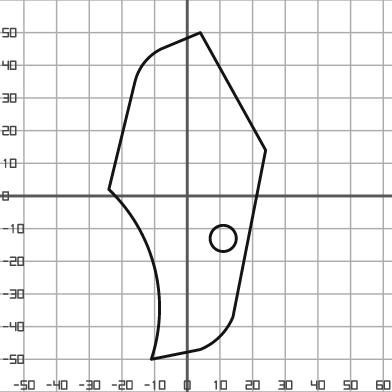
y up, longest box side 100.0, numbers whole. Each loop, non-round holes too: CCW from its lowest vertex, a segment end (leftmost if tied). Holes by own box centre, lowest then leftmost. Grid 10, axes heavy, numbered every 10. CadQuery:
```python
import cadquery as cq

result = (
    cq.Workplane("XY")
    .moveTo(-11.0, -50.0)
    .lineTo(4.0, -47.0)
    .threePointArc((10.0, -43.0), (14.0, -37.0))
    .lineTo(24.0, 14.0)
    .lineTo(4.0, 50.0)
    .lineTo(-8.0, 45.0)
    .threePointArc((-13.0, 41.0), (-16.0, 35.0))
    .lineTo(-24.0, 2.0)
    .threePointArc((-10.0, -22.0), (-11.0, -50.0))
    .close()
    .moveTo(11.0, -13.0)
    .circle(4.0)
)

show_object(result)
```